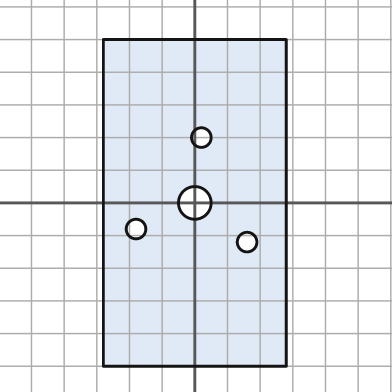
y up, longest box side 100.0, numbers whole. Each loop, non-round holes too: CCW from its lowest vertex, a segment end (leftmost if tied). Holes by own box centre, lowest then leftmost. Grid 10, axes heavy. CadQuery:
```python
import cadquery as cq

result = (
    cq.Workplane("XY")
    .moveTo(-28.0, -50.0)
    .lineTo(28.0, -50.0)
    .lineTo(28.0, 50.0)
    .lineTo(-28.0, 50.0)
    .close()
    .moveTo(16.0, -12.0)
    .circle(3.0)
    .moveTo(-18.0, -8.0)
    .circle(3.0)
    .moveTo(0.0, 0.0)
    .circle(5.0)
    .moveTo(2.0, 20.0)
    .circle(3.0)
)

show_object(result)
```